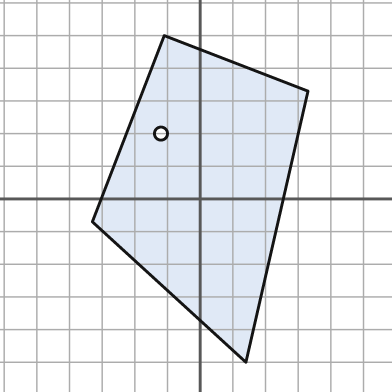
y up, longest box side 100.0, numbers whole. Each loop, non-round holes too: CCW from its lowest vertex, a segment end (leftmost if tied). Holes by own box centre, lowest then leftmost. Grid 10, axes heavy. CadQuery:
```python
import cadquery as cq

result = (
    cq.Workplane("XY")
    .moveTo(14.0, -50.0)
    .lineTo(33.0, 33.0)
    .lineTo(-11.0, 50.0)
    .lineTo(-33.0, -7.0)
    .close()
    .moveTo(-12.0, 20.0)
    .circle(2.0)
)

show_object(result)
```